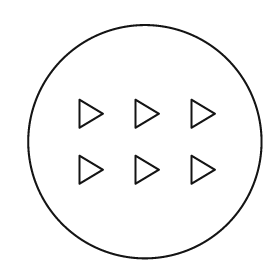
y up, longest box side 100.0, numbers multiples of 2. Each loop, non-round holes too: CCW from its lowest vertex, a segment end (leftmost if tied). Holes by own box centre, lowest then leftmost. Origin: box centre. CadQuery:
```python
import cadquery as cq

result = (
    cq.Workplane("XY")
    .moveTo(0.0, 0.0)
    .circle(50.0)
    .moveTo(-28.0, -18.0)
    .lineTo(-18.0, -12.0)
    .lineTo(-28.0, -6.0)
    .close()
    .moveTo(-4.0, -18.0)
    .lineTo(6.0, -12.0)
    .lineTo(-4.0, -6.0)
    .close()
    .moveTo(20.0, -18.0)
    .lineTo(30.0, -12.0)
    .lineTo(20.0, -6.0)
    .close()
    .moveTo(-28.0, 6.0)
    .lineTo(-18.0, 12.0)
    .lineTo(-28.0, 18.0)
    .close()
    .moveTo(-4.0, 6.0)
    .lineTo(6.0, 12.0)
    .lineTo(-4.0, 18.0)
    .close()
    .moveTo(20.0, 6.0)
    .lineTo(30.0, 12.0)
    .lineTo(20.0, 18.0)
    .close()
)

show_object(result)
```